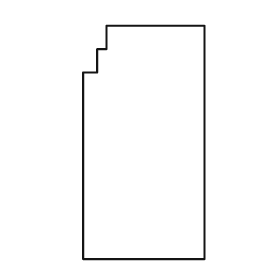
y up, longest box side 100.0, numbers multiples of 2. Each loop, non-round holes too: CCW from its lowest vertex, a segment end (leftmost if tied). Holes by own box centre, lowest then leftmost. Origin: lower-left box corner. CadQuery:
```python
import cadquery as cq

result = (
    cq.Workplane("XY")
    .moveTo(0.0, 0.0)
    .lineTo(52.0, 0.0)
    .lineTo(52.0, 100.0)
    .lineTo(10.0, 100.0)
    .lineTo(10.0, 90.0)
    .lineTo(6.0, 90.0)
    .lineTo(6.0, 80.0)
    .lineTo(0.0, 80.0)
    .close()
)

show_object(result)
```